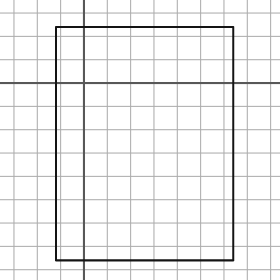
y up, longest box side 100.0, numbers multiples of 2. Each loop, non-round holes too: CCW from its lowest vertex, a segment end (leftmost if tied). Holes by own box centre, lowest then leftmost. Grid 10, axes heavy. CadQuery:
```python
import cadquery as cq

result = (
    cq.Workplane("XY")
    .moveTo(-12.0, -76.0)
    .lineTo(64.0, -76.0)
    .lineTo(64.0, 24.0)
    .lineTo(-12.0, 24.0)
    .close()
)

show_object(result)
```